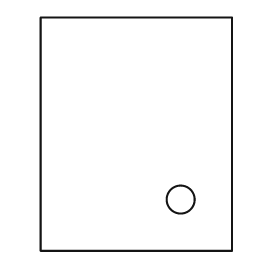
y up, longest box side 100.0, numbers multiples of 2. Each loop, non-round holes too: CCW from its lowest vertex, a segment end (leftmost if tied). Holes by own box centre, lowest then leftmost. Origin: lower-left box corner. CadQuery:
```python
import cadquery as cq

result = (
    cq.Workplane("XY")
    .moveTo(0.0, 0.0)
    .lineTo(82.0, 0.0)
    .lineTo(82.0, 100.0)
    .lineTo(0.0, 100.0)
    .close()
    .moveTo(60.0, 22.0)
    .circle(6.0)
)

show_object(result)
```